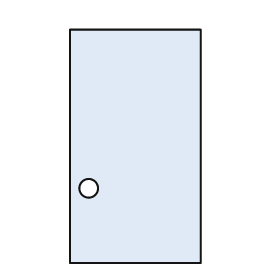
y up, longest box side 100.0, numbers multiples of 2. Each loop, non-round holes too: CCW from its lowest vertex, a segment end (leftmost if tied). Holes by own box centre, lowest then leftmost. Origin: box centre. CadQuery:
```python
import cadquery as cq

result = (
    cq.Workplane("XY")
    .moveTo(-28.0, -50.0)
    .lineTo(28.0, -50.0)
    .lineTo(28.0, 50.0)
    .lineTo(-28.0, 50.0)
    .close()
    .moveTo(-20.0, -18.0)
    .circle(4.0)
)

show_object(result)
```